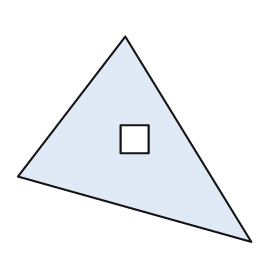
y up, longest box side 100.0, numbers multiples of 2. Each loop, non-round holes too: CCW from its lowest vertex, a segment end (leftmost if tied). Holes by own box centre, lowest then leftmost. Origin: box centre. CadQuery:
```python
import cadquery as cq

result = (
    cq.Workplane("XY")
    .moveTo(50.0, -44.0)
    .lineTo(-4.0, 44.0)
    .lineTo(-50.0, -16.0)
    .close()
    .moveTo(-6.0, -6.0)
    .lineTo(6.0, -6.0)
    .lineTo(6.0, 6.0)
    .lineTo(-6.0, 6.0)
    .close()
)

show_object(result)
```